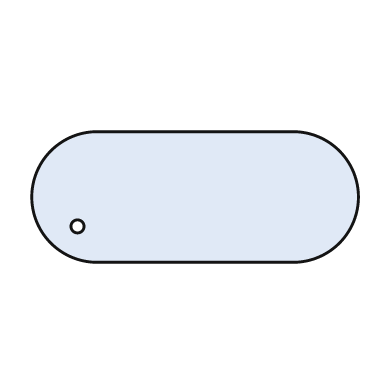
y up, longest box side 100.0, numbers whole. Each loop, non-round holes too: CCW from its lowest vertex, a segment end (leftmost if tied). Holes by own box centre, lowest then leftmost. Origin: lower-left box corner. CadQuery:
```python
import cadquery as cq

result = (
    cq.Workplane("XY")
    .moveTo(20.0, 0.0)
    .lineTo(80.0, 0.0)
    .threePointArc((100.0, 20.0), (80.0, 40.0))
    .lineTo(20.0, 40.0)
    .threePointArc((0.0, 20.0), (20.0, 0.0))
    .close()
    .moveTo(14.0, 11.0)
    .circle(2.0)
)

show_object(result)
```